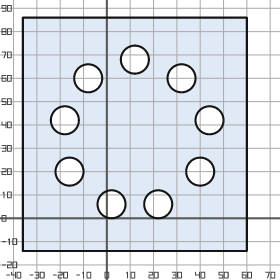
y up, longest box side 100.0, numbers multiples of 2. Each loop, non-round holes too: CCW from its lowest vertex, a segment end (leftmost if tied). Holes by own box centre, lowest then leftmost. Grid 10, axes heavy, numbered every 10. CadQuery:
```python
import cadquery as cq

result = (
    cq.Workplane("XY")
    .moveTo(-36.0, -14.0)
    .lineTo(60.0, -14.0)
    .lineTo(60.0, 86.0)
    .lineTo(-36.0, 86.0)
    .close()
    .moveTo(2.0, 6.0)
    .circle(6.0)
    .moveTo(22.0, 6.0)
    .circle(6.0)
    .moveTo(-16.0, 20.0)
    .circle(6.0)
    .moveTo(40.0, 20.0)
    .circle(6.0)
    .moveTo(-18.0, 42.0)
    .circle(6.0)
    .moveTo(44.0, 42.0)
    .circle(6.0)
    .moveTo(-8.0, 60.0)
    .circle(6.0)
    .moveTo(32.0, 60.0)
    .circle(6.0)
    .moveTo(12.0, 68.0)
    .circle(6.0)
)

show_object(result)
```